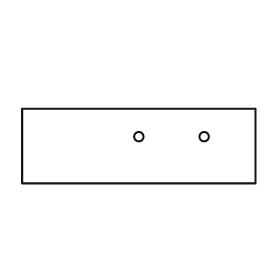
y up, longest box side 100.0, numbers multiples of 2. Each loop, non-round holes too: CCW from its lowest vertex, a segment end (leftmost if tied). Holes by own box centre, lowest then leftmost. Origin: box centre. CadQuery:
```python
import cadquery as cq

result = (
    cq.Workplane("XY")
    .moveTo(-50.0, -16.0)
    .lineTo(50.0, -16.0)
    .lineTo(50.0, 16.0)
    .lineTo(-50.0, 16.0)
    .close()
    .moveTo(0.0, 4.0)
    .circle(2.0)
    .moveTo(28.0, 4.0)
    .circle(2.0)
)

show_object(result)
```